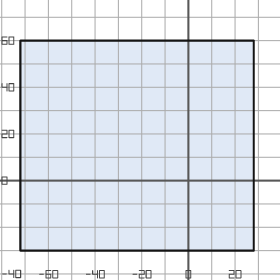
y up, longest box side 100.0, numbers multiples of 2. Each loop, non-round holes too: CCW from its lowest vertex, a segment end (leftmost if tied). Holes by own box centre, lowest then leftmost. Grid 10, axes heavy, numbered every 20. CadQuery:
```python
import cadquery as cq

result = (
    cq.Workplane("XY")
    .moveTo(-72.0, -30.0)
    .lineTo(28.0, -30.0)
    .lineTo(28.0, 60.0)
    .lineTo(-72.0, 60.0)
    .close()
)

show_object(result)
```